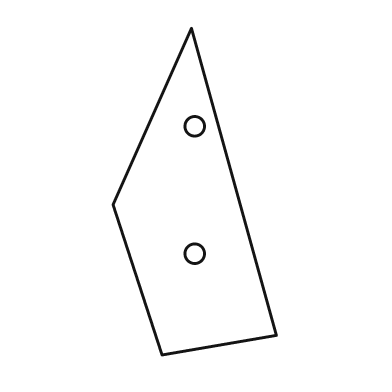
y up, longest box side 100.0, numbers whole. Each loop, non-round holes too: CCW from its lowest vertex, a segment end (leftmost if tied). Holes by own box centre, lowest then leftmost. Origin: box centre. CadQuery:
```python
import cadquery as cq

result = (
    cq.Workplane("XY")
    .moveTo(-10.0, -50.0)
    .lineTo(25.0, -44.0)
    .lineTo(-1.0, 50.0)
    .lineTo(-25.0, -4.0)
    .close()
    .moveTo(0.0, -19.0)
    .circle(3.0)
    .moveTo(0.0, 20.0)
    .circle(3.0)
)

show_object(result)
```